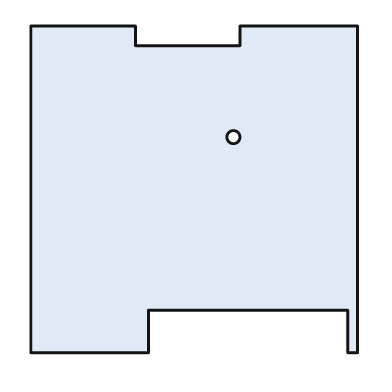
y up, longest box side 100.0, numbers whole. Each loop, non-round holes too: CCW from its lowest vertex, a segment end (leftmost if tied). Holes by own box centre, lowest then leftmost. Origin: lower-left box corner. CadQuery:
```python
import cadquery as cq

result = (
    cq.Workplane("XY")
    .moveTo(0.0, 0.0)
    .lineTo(36.0, 0.0)
    .lineTo(36.0, 13.0)
    .lineTo(97.0, 13.0)
    .lineTo(97.0, 0.0)
    .lineTo(100.0, 0.0)
    .lineTo(100.0, 100.0)
    .lineTo(64.0, 100.0)
    .lineTo(64.0, 94.0)
    .lineTo(32.0, 94.0)
    .lineTo(32.0, 100.0)
    .lineTo(0.0, 100.0)
    .close()
    .moveTo(62.0, 66.0)
    .circle(2.0)
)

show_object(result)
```